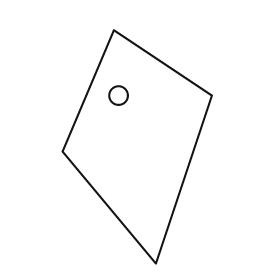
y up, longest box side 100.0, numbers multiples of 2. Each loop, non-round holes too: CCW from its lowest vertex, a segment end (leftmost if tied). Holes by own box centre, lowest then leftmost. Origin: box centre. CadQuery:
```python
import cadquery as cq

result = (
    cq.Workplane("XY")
    .moveTo(8.0, -50.0)
    .lineTo(32.0, 22.0)
    .lineTo(-10.0, 50.0)
    .lineTo(-32.0, -2.0)
    .close()
    .moveTo(-8.0, 22.0)
    .circle(4.0)
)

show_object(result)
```